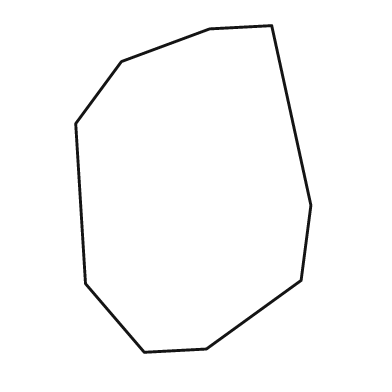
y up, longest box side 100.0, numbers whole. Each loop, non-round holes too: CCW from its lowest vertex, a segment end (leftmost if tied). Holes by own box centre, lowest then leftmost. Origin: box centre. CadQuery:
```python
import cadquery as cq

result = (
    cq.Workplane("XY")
    .moveTo(-15.0, -50.0)
    .lineTo(4.0, -49.0)
    .lineTo(33.0, -28.0)
    .lineTo(36.0, -5.0)
    .lineTo(24.0, 50.0)
    .lineTo(5.0, 49.0)
    .lineTo(-22.0, 39.0)
    .lineTo(-36.0, 20.0)
    .lineTo(-33.0, -29.0)
    .close()
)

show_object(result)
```